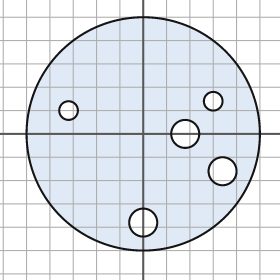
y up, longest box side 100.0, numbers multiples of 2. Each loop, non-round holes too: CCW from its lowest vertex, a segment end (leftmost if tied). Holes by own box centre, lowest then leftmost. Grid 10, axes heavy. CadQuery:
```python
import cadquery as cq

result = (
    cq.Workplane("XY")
    .moveTo(0.0, 0.0)
    .circle(50.0)
    .moveTo(0.0, -38.0)
    .circle(6.0)
    .moveTo(34.0, -16.0)
    .circle(6.0)
    .moveTo(18.0, 0.0)
    .circle(6.0)
    .moveTo(-32.0, 10.0)
    .circle(4.0)
    .moveTo(30.0, 14.0)
    .circle(4.0)
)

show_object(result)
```